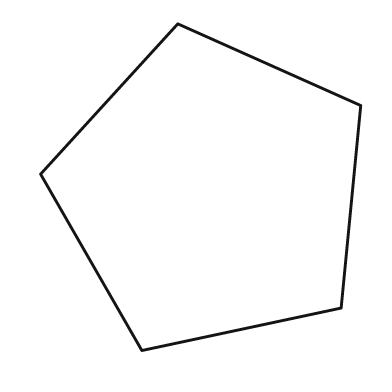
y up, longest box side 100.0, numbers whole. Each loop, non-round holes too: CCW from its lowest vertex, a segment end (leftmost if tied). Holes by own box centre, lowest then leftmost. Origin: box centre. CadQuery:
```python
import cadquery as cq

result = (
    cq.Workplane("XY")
    .moveTo(-18.0, -50.0)
    .lineTo(43.0, -37.0)
    .lineTo(49.0, 25.0)
    .lineTo(-7.0, 50.0)
    .lineTo(-49.0, 4.0)
    .close()
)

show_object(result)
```